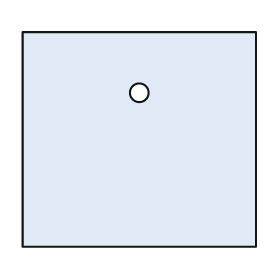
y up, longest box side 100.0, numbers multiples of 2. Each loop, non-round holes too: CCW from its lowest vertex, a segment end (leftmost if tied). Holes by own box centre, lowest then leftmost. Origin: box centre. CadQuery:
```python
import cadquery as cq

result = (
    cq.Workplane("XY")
    .moveTo(-50.0, -46.0)
    .lineTo(50.0, -46.0)
    .lineTo(50.0, 46.0)
    .lineTo(-50.0, 46.0)
    .close()
    .moveTo(0.0, 20.0)
    .circle(4.0)
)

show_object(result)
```